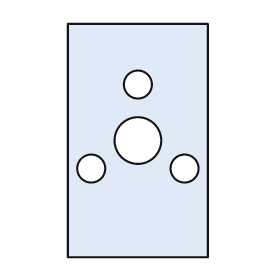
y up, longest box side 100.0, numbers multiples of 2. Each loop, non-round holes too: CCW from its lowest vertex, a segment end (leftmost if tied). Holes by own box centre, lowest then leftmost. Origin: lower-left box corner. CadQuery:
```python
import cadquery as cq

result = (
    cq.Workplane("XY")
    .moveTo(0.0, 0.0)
    .lineTo(60.0, 0.0)
    .lineTo(60.0, 100.0)
    .lineTo(0.0, 100.0)
    .close()
    .moveTo(10.0, 38.0)
    .circle(6.0)
    .moveTo(50.0, 38.0)
    .circle(6.0)
    .moveTo(30.0, 50.0)
    .circle(10.0)
    .moveTo(30.0, 74.0)
    .circle(6.0)
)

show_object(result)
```